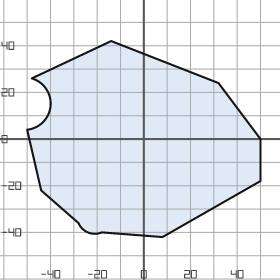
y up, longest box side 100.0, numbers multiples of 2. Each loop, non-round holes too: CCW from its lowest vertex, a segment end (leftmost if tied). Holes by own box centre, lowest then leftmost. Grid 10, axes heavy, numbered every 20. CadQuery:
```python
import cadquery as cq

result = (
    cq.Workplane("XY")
    .moveTo(8.0, -42.0)
    .lineTo(50.0, -18.0)
    .lineTo(50.0, 0.0)
    .lineTo(32.0, 24.0)
    .lineTo(-14.0, 42.0)
    .lineTo(-48.0, 26.0)
    .threePointArc((-40.0, 14.0), (-50.0, 4.0))
    .lineTo(-44.0, -22.0)
    .lineTo(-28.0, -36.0)
    .threePointArc((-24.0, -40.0), (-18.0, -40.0))
    .close()
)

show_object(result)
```